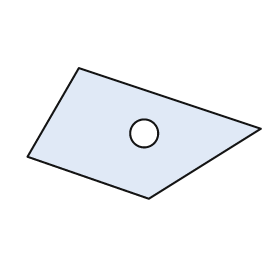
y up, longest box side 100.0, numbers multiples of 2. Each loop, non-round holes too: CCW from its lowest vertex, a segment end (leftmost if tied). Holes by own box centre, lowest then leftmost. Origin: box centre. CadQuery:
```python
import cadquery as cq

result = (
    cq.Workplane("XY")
    .moveTo(2.0, -28.0)
    .lineTo(50.0, 2.0)
    .lineTo(-28.0, 28.0)
    .lineTo(-50.0, -10.0)
    .close()
    .moveTo(0.0, 0.0)
    .circle(6.0)
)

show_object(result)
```